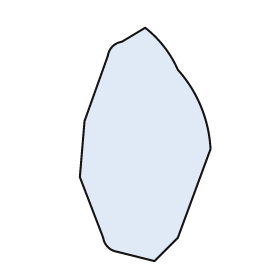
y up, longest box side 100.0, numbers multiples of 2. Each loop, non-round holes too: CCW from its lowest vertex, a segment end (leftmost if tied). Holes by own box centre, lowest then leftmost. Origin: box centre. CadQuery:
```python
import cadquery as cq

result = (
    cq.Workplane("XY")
    .moveTo(4.0, -50.0)
    .lineTo(14.0, -40.0)
    .lineTo(28.0, -2.0)
    .threePointArc((24.0, 16.0), (14.0, 32.0))
    .threePointArc((8.0, 42.0), (0.0, 50.0))
    .lineTo(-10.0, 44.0)
    .threePointArc((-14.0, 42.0), (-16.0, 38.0))
    .lineTo(-26.0, 10.0)
    .lineTo(-28.0, -14.0)
    .lineTo(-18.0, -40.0)
    .threePointArc((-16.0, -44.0), (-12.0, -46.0))
    .close()
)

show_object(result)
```